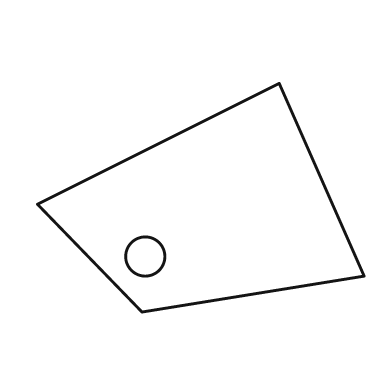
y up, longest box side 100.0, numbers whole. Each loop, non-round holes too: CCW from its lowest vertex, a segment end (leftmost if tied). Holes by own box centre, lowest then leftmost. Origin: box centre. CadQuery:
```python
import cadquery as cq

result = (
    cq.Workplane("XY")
    .moveTo(-18.0, -35.0)
    .lineTo(50.0, -24.0)
    .lineTo(24.0, 35.0)
    .lineTo(-50.0, -2.0)
    .close()
    .moveTo(-17.0, -18.0)
    .circle(6.0)
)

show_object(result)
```